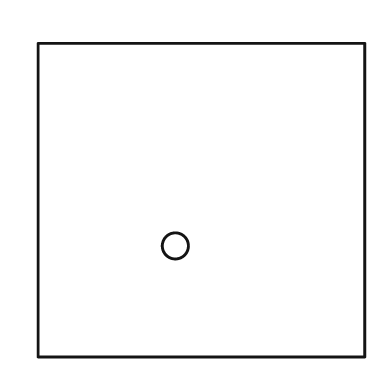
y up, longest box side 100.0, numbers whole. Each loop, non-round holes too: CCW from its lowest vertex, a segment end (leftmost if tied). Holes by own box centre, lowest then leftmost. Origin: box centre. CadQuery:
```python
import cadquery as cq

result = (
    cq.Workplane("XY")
    .moveTo(-50.0, -48.0)
    .lineTo(50.0, -48.0)
    .lineTo(50.0, 48.0)
    .lineTo(-50.0, 48.0)
    .close()
    .moveTo(-8.0, -14.0)
    .circle(4.0)
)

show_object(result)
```